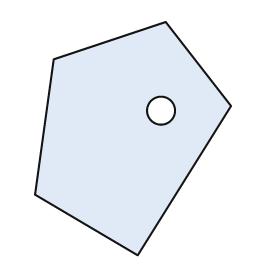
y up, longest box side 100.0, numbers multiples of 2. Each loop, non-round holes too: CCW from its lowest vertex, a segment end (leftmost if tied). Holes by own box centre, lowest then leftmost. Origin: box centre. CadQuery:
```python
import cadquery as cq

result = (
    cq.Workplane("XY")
    .moveTo(2.0, -50.0)
    .lineTo(42.0, 14.0)
    .lineTo(14.0, 50.0)
    .lineTo(-34.0, 34.0)
    .lineTo(-42.0, -24.0)
    .close()
    .moveTo(12.0, 12.0)
    .circle(6.0)
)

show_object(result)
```